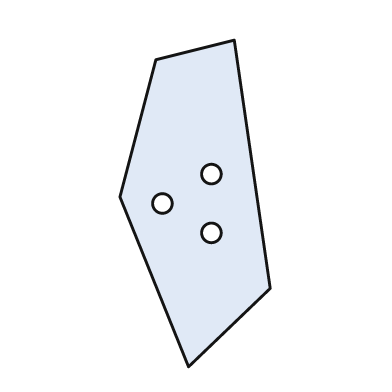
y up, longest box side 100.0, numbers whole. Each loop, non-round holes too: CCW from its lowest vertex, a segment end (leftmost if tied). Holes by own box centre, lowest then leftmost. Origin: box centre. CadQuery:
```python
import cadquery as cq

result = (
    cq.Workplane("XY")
    .moveTo(-2.0, -50.0)
    .lineTo(23.0, -26.0)
    .lineTo(12.0, 50.0)
    .lineTo(-12.0, 44.0)
    .lineTo(-23.0, 2.0)
    .close()
    .moveTo(5.0, -9.0)
    .circle(3.0)
    .moveTo(-10.0, 0.0)
    .circle(3.0)
    .moveTo(5.0, 9.0)
    .circle(3.0)
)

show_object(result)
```